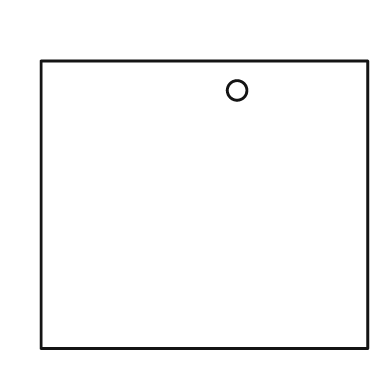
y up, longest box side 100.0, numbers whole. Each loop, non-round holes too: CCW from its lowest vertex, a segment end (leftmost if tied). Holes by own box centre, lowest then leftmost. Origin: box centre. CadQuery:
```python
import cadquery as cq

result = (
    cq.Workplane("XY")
    .moveTo(-50.0, -44.0)
    .lineTo(50.0, -44.0)
    .lineTo(50.0, 44.0)
    .lineTo(-50.0, 44.0)
    .close()
    .moveTo(10.0, 35.0)
    .circle(3.0)
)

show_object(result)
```